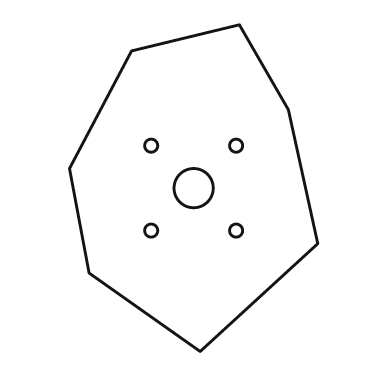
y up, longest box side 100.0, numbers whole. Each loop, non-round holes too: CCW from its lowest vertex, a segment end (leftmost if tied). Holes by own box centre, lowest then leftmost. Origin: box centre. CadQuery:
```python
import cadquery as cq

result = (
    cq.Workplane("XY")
    .moveTo(2.0, -50.0)
    .lineTo(38.0, -17.0)
    .lineTo(29.0, 24.0)
    .lineTo(14.0, 50.0)
    .lineTo(-19.0, 42.0)
    .lineTo(-38.0, 6.0)
    .lineTo(-32.0, -26.0)
    .close()
    .moveTo(-13.0, -13.0)
    .circle(2.0)
    .moveTo(13.0, -13.0)
    .circle(2.0)
    .moveTo(0.0, 0.0)
    .circle(6.0)
    .moveTo(-13.0, 13.0)
    .circle(2.0)
    .moveTo(13.0, 13.0)
    .circle(2.0)
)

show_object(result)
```